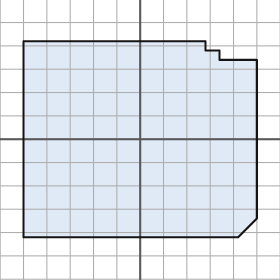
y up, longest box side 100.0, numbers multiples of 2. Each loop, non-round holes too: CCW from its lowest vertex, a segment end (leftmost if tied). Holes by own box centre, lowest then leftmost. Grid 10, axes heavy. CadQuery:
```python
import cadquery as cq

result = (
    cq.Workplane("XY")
    .moveTo(-50.0, -42.0)
    .lineTo(42.0, -42.0)
    .lineTo(50.0, -34.0)
    .lineTo(50.0, 34.0)
    .lineTo(34.0, 34.0)
    .lineTo(34.0, 38.0)
    .lineTo(28.0, 38.0)
    .lineTo(28.0, 42.0)
    .lineTo(-50.0, 42.0)
    .close()
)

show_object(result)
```